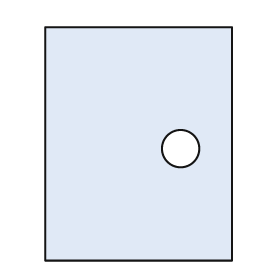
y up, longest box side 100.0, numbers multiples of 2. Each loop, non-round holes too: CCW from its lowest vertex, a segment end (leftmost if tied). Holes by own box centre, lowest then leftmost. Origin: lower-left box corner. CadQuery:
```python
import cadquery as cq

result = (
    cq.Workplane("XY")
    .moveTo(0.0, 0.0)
    .lineTo(80.0, 0.0)
    .lineTo(80.0, 100.0)
    .lineTo(0.0, 100.0)
    .close()
    .moveTo(58.0, 48.0)
    .circle(8.0)
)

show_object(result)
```